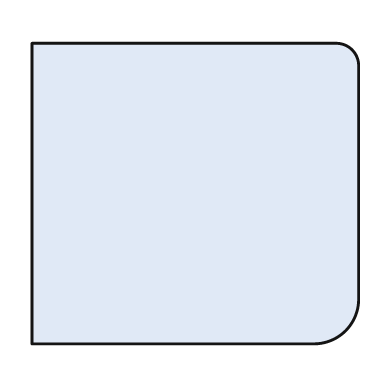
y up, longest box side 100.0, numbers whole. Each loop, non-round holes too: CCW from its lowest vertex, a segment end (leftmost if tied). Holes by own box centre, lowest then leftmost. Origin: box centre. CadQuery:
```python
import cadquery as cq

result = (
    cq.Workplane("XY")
    .moveTo(-50.0, -46.0)
    .lineTo(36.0, -46.0)
    .threePointArc((46.0, -42.0), (50.0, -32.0))
    .lineTo(50.0, 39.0)
    .threePointArc((48.0, 44.0), (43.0, 46.0))
    .lineTo(-50.0, 46.0)
    .close()
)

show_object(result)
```